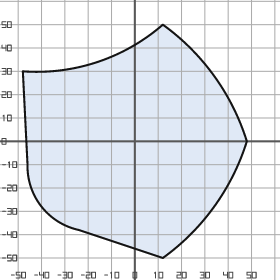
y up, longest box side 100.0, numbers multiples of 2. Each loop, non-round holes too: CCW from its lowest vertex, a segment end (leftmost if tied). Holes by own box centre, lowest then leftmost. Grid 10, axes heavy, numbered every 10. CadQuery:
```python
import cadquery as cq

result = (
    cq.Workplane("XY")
    .moveTo(12.0, -50.0)
    .threePointArc((34.0, -28.0), (48.0, 0.0))
    .threePointArc((34.0, 28.0), (12.0, 50.0))
    .threePointArc((-16.0, 34.0), (-48.0, 30.0))
    .lineTo(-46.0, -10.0)
    .threePointArc((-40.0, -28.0), (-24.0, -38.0))
    .close()
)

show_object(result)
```